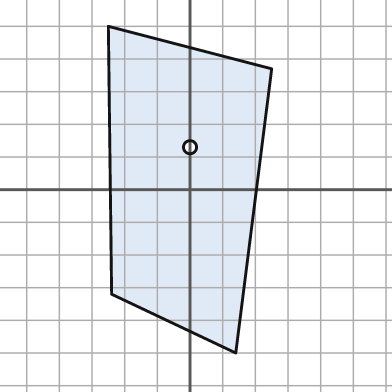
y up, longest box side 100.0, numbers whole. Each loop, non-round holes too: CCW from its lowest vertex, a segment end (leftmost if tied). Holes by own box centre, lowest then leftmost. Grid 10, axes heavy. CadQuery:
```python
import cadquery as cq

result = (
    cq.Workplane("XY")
    .moveTo(14.0, -50.0)
    .lineTo(25.0, 37.0)
    .lineTo(-25.0, 50.0)
    .lineTo(-24.0, -32.0)
    .close()
    .moveTo(0.0, 13.0)
    .circle(2.0)
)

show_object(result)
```